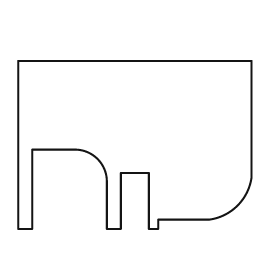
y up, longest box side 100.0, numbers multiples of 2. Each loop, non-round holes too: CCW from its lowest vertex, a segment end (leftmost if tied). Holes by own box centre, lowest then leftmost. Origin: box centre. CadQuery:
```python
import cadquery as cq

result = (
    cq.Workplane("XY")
    .moveTo(-50.0, -36.0)
    .lineTo(-44.0, -36.0)
    .lineTo(-44.0, -2.0)
    .lineTo(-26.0, -2.0)
    .threePointArc((-16.0, -6.0), (-12.0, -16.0))
    .lineTo(-12.0, -36.0)
    .lineTo(-6.0, -36.0)
    .lineTo(-6.0, -12.0)
    .lineTo(6.0, -12.0)
    .lineTo(6.0, -36.0)
    .lineTo(10.0, -36.0)
    .lineTo(10.0, -32.0)
    .lineTo(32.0, -32.0)
    .threePointArc((44.0, -26.0), (50.0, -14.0))
    .lineTo(50.0, 36.0)
    .lineTo(-50.0, 36.0)
    .close()
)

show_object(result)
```